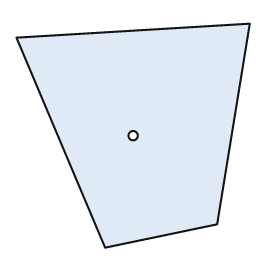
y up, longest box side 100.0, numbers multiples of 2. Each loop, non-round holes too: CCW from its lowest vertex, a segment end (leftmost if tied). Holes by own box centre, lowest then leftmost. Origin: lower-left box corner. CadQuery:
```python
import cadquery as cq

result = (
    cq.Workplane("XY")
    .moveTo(38.0, 0.0)
    .lineTo(86.0, 10.0)
    .lineTo(100.0, 96.0)
    .lineTo(0.0, 90.0)
    .close()
    .moveTo(50.0, 48.0)
    .circle(2.0)
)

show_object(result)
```